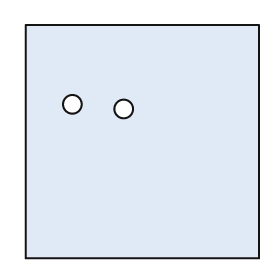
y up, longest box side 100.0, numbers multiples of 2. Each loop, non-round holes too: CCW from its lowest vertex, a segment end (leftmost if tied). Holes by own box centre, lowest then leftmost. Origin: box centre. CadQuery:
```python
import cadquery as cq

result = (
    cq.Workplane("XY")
    .moveTo(-50.0, -50.0)
    .lineTo(50.0, -50.0)
    .lineTo(50.0, 50.0)
    .lineTo(-50.0, 50.0)
    .close()
    .moveTo(-8.0, 14.0)
    .circle(4.0)
    .moveTo(-30.0, 16.0)
    .circle(4.0)
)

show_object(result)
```